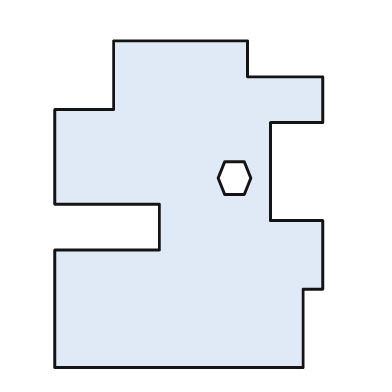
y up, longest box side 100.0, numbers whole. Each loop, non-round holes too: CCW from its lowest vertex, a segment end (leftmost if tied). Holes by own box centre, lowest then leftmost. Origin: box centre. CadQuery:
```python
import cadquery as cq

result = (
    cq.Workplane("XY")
    .moveTo(-41.0, -50.0)
    .lineTo(35.0, -50.0)
    .lineTo(35.0, -26.0)
    .lineTo(41.0, -26.0)
    .lineTo(41.0, -5.0)
    .lineTo(25.0, -5.0)
    .lineTo(25.0, 25.0)
    .lineTo(41.0, 25.0)
    .lineTo(41.0, 39.0)
    .lineTo(18.0, 39.0)
    .lineTo(18.0, 50.0)
    .lineTo(-23.0, 50.0)
    .lineTo(-23.0, 29.0)
    .lineTo(-41.0, 29.0)
    .lineTo(-41.0, 0.0)
    .lineTo(-9.0, 0.0)
    .lineTo(-9.0, -14.0)
    .lineTo(-41.0, -14.0)
    .close()
    .moveTo(11.0, 3.0)
    .lineTo(17.0, 3.0)
    .lineTo(19.0, 8.0)
    .lineTo(17.0, 13.0)
    .lineTo(11.0, 13.0)
    .lineTo(9.0, 8.0)
    .close()
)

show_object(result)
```